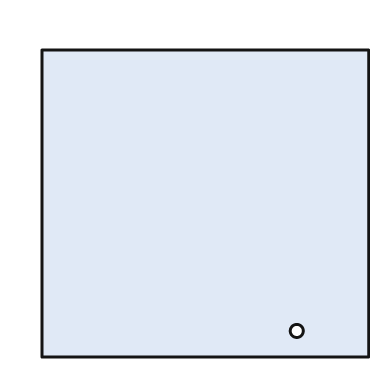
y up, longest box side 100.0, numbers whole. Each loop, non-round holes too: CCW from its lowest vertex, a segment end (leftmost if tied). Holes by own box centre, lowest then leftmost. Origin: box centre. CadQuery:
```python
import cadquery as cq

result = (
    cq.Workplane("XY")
    .moveTo(-50.0, -47.0)
    .lineTo(50.0, -47.0)
    .lineTo(50.0, 47.0)
    .lineTo(-50.0, 47.0)
    .close()
    .moveTo(28.0, -39.0)
    .circle(2.0)
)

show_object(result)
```